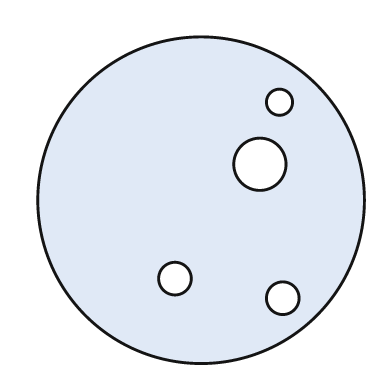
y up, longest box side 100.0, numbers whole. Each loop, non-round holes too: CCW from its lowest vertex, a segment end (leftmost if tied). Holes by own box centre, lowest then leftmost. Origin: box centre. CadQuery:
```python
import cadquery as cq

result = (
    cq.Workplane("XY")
    .moveTo(0.0, 0.0)
    .circle(50.0)
    .moveTo(25.0, -30.0)
    .circle(5.0)
    .moveTo(-8.0, -24.0)
    .circle(5.0)
    .moveTo(18.0, 11.0)
    .circle(8.0)
    .moveTo(24.0, 30.0)
    .circle(4.0)
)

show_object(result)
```